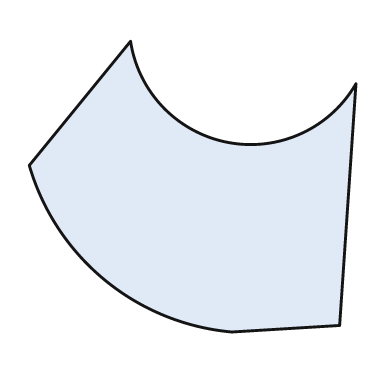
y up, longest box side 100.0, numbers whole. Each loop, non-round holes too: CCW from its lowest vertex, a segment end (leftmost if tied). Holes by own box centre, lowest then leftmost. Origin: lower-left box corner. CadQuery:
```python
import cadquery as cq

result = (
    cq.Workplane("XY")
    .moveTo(62.0, 0.0)
    .lineTo(95.0, 2.0)
    .lineTo(100.0, 76.0)
    .threePointArc((61.0, 58.0), (31.0, 89.0))
    .lineTo(0.0, 51.0)
    .threePointArc((23.0, 16.0), (62.0, 0.0))
    .close()
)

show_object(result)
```